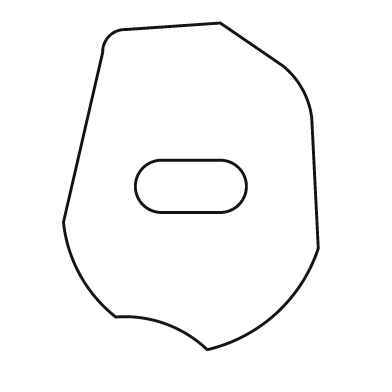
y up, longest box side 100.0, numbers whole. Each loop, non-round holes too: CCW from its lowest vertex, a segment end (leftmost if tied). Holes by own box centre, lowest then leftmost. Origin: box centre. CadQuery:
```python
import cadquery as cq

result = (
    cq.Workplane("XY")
    .moveTo(5.0, -50.0)
    .threePointArc((26.0, -39.0), (39.0, -19.0))
    .lineTo(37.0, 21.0)
    .threePointArc((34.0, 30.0), (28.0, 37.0))
    .lineTo(9.0, 50.0)
    .lineTo(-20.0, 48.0)
    .threePointArc((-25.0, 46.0), (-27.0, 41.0))
    .lineTo(-39.0, -11.0)
    .threePointArc((-34.0, -27.0), (-23.0, -40.0))
    .threePointArc((-8.0, -42.0), (5.0, -50.0))
    .close()
    .moveTo(-9.0, -8.0)
    .lineTo(9.0, -8.0)
    .threePointArc((17.0, 0.0), (9.0, 8.0))
    .lineTo(-9.0, 8.0)
    .threePointArc((-17.0, 0.0), (-9.0, -8.0))
    .close()
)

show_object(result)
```